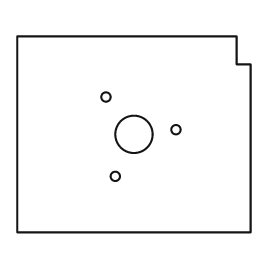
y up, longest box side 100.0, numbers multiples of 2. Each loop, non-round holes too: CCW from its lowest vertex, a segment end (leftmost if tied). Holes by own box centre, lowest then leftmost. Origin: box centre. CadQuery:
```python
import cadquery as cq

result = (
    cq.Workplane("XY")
    .moveTo(-50.0, -42.0)
    .lineTo(50.0, -42.0)
    .lineTo(50.0, 30.0)
    .lineTo(44.0, 30.0)
    .lineTo(44.0, 42.0)
    .lineTo(-50.0, 42.0)
    .close()
    .moveTo(-8.0, -18.0)
    .circle(2.0)
    .moveTo(0.0, 0.0)
    .circle(8.0)
    .moveTo(18.0, 2.0)
    .circle(2.0)
    .moveTo(-12.0, 16.0)
    .circle(2.0)
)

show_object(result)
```